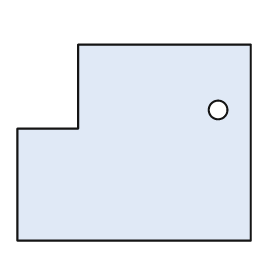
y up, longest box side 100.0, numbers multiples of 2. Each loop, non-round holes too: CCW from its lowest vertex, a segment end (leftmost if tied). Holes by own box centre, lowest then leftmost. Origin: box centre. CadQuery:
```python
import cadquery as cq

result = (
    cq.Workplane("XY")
    .moveTo(-50.0, -42.0)
    .lineTo(50.0, -42.0)
    .lineTo(50.0, 42.0)
    .lineTo(-24.0, 42.0)
    .lineTo(-24.0, 6.0)
    .lineTo(-50.0, 6.0)
    .close()
    .moveTo(36.0, 14.0)
    .circle(4.0)
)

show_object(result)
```